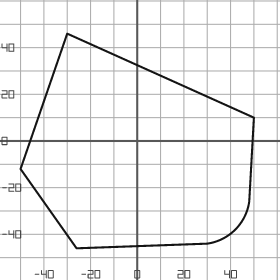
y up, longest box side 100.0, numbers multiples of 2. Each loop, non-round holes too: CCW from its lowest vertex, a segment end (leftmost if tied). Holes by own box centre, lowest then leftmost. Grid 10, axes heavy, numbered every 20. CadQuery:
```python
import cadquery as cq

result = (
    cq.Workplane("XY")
    .moveTo(-26.0, -46.0)
    .lineTo(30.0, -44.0)
    .threePointArc((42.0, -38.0), (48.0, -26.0))
    .lineTo(50.0, 10.0)
    .lineTo(-30.0, 46.0)
    .lineTo(-50.0, -12.0)
    .close()
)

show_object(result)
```